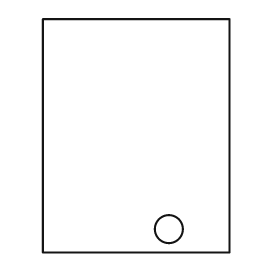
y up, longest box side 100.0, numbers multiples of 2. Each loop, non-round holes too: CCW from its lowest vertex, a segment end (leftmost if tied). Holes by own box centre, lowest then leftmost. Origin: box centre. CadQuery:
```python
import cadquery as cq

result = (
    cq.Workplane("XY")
    .moveTo(-40.0, -50.0)
    .lineTo(40.0, -50.0)
    .lineTo(40.0, 50.0)
    .lineTo(-40.0, 50.0)
    .close()
    .moveTo(14.0, -40.0)
    .circle(6.0)
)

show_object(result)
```